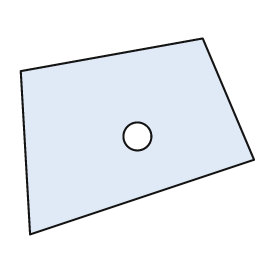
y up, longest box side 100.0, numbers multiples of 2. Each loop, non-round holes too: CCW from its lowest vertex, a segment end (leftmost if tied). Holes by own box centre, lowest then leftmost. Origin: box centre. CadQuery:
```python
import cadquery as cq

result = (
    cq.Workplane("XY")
    .moveTo(-46.0, -42.0)
    .lineTo(50.0, -10.0)
    .lineTo(28.0, 42.0)
    .lineTo(-50.0, 28.0)
    .close()
    .moveTo(0.0, 0.0)
    .circle(6.0)
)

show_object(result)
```